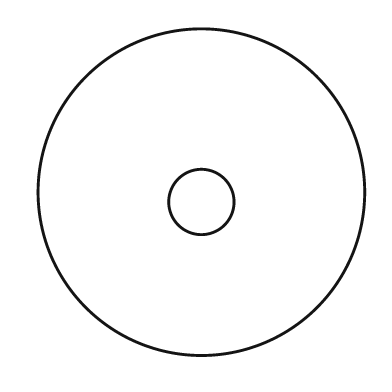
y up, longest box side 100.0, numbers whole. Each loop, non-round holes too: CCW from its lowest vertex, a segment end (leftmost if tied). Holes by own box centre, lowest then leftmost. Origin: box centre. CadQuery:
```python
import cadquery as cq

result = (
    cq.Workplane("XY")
    .moveTo(0.0, 0.0)
    .circle(50.0)
    .moveTo(0.0, -3.0)
    .circle(10.0)
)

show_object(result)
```